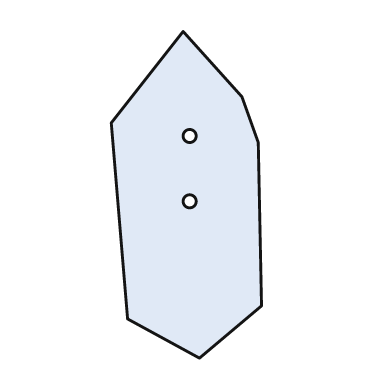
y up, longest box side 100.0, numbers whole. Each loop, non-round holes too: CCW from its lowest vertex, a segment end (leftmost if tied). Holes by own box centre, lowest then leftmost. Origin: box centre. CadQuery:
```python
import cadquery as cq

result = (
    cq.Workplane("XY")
    .moveTo(4.0, -50.0)
    .lineTo(23.0, -34.0)
    .lineTo(22.0, 16.0)
    .lineTo(17.0, 30.0)
    .lineTo(-1.0, 50.0)
    .lineTo(-23.0, 22.0)
    .lineTo(-18.0, -38.0)
    .close()
    .moveTo(1.0, -2.0)
    .circle(2.0)
    .moveTo(1.0, 18.0)
    .circle(2.0)
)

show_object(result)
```